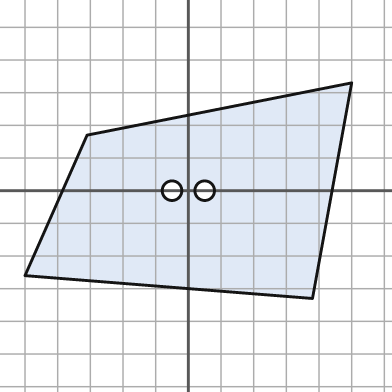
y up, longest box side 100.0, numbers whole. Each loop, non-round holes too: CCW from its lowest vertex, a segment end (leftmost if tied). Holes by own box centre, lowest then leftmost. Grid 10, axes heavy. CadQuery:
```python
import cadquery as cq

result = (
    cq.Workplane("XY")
    .moveTo(38.0, -33.0)
    .lineTo(50.0, 33.0)
    .lineTo(-31.0, 17.0)
    .lineTo(-50.0, -26.0)
    .close()
    .moveTo(-5.0, 0.0)
    .circle(3.0)
    .moveTo(5.0, 0.0)
    .circle(3.0)
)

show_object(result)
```